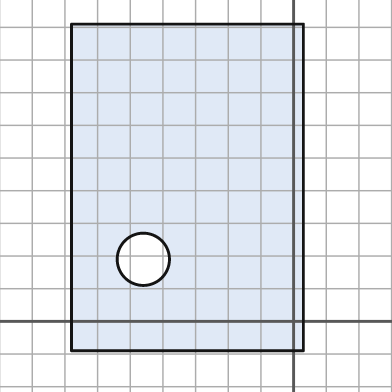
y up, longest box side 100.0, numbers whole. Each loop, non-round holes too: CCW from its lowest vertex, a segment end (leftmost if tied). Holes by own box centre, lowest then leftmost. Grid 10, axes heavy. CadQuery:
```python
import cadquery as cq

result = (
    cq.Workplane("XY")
    .moveTo(-68.0, -9.0)
    .lineTo(3.0, -9.0)
    .lineTo(3.0, 91.0)
    .lineTo(-68.0, 91.0)
    .close()
    .moveTo(-46.0, 19.0)
    .circle(8.0)
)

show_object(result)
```